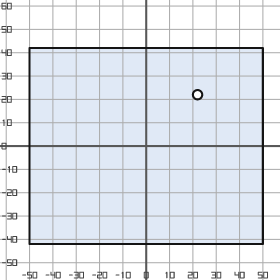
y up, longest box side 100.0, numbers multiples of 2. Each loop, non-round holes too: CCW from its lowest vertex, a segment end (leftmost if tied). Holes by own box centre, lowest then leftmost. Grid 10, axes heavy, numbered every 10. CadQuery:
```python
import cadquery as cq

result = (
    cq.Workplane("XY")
    .moveTo(-50.0, -42.0)
    .lineTo(50.0, -42.0)
    .lineTo(50.0, 42.0)
    .lineTo(-50.0, 42.0)
    .close()
    .moveTo(22.0, 22.0)
    .circle(2.0)
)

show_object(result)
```